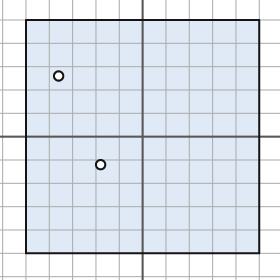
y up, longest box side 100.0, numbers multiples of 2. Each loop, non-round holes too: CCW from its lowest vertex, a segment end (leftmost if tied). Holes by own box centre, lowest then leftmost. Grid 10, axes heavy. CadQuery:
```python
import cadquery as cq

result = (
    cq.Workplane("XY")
    .moveTo(-50.0, -50.0)
    .lineTo(50.0, -50.0)
    .lineTo(50.0, 50.0)
    .lineTo(-50.0, 50.0)
    .close()
    .moveTo(-18.0, -12.0)
    .circle(2.0)
    .moveTo(-36.0, 26.0)
    .circle(2.0)
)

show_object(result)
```